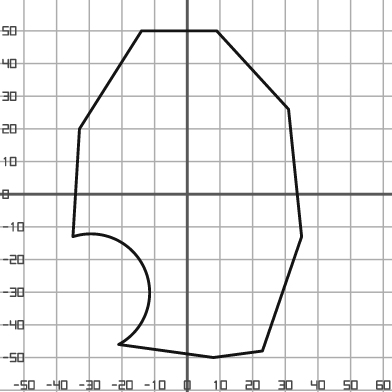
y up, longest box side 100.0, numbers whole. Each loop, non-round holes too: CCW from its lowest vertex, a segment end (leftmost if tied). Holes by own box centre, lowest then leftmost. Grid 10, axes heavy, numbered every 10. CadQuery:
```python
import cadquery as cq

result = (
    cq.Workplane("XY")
    .moveTo(8.0, -50.0)
    .lineTo(23.0, -48.0)
    .lineTo(35.0, -13.0)
    .lineTo(31.0, 26.0)
    .lineTo(9.0, 50.0)
    .lineTo(-14.0, 50.0)
    .lineTo(-33.0, 20.0)
    .lineTo(-35.0, -13.0)
    .threePointArc((-13.0, -23.0), (-21.0, -46.0))
    .close()
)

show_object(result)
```